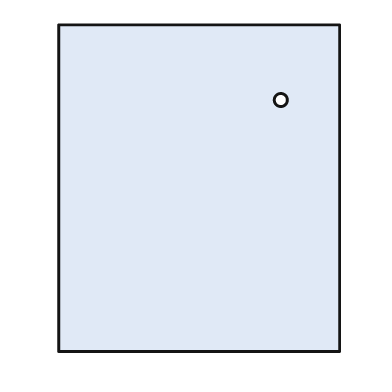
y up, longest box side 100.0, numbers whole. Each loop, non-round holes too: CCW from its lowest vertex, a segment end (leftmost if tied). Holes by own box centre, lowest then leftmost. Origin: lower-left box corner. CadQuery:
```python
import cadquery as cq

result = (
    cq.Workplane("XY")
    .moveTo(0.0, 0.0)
    .lineTo(86.0, 0.0)
    .lineTo(86.0, 100.0)
    .lineTo(0.0, 100.0)
    .close()
    .moveTo(68.0, 77.0)
    .circle(2.0)
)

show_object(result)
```